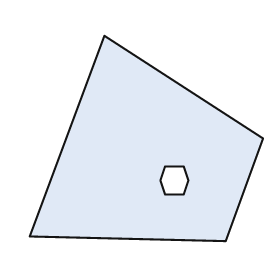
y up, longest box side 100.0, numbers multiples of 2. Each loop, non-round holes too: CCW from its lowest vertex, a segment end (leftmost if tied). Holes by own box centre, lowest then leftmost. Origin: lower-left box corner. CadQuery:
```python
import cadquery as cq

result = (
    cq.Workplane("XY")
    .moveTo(84.0, 0.0)
    .lineTo(100.0, 44.0)
    .lineTo(32.0, 88.0)
    .lineTo(0.0, 2.0)
    .close()
    .moveTo(58.0, 20.0)
    .lineTo(66.0, 20.0)
    .lineTo(68.0, 26.0)
    .lineTo(66.0, 32.0)
    .lineTo(58.0, 32.0)
    .lineTo(56.0, 26.0)
    .close()
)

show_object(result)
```